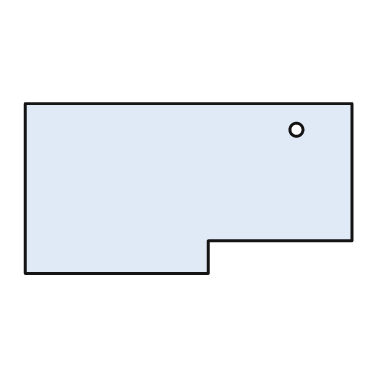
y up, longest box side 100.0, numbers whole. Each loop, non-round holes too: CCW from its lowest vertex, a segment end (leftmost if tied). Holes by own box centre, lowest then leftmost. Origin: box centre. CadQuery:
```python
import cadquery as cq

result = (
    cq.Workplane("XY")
    .moveTo(-50.0, -26.0)
    .lineTo(6.0, -26.0)
    .lineTo(6.0, -16.0)
    .lineTo(50.0, -16.0)
    .lineTo(50.0, 26.0)
    .lineTo(-50.0, 26.0)
    .close()
    .moveTo(33.0, 18.0)
    .circle(2.0)
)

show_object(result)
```